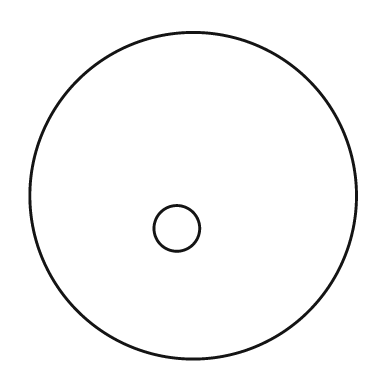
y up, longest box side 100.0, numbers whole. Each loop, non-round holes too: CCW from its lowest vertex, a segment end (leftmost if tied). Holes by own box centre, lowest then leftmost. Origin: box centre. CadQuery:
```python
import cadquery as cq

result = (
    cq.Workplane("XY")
    .moveTo(0.0, 0.0)
    .circle(50.0)
    .moveTo(-5.0, -10.0)
    .circle(7.0)
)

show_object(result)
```